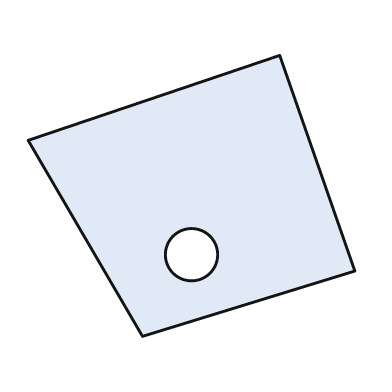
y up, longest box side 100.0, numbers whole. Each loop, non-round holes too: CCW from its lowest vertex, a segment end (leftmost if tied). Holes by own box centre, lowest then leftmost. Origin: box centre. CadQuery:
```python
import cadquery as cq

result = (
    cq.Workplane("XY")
    .moveTo(-15.0, -43.0)
    .lineTo(50.0, -23.0)
    .lineTo(27.0, 43.0)
    .lineTo(-50.0, 17.0)
    .close()
    .moveTo(0.0, -18.0)
    .circle(8.0)
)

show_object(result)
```